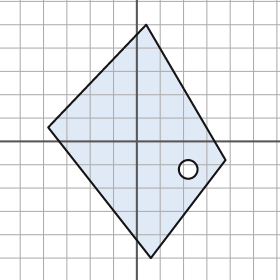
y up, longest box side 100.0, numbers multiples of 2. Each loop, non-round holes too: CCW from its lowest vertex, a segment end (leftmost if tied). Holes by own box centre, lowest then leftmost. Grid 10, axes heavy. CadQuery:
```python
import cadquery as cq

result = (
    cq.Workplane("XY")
    .moveTo(6.0, -50.0)
    .lineTo(38.0, -8.0)
    .lineTo(4.0, 50.0)
    .lineTo(-38.0, 6.0)
    .close()
    .moveTo(22.0, -12.0)
    .circle(4.0)
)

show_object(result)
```